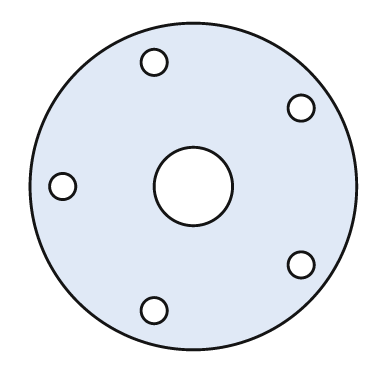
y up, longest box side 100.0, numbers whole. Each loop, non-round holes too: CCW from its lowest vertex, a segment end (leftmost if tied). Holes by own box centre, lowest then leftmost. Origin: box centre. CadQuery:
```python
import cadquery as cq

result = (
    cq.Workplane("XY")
    .moveTo(0.0, 0.0)
    .circle(50.0)
    .moveTo(-12.0, -38.0)
    .circle(4.0)
    .moveTo(33.0, -24.0)
    .circle(4.0)
    .moveTo(-40.0, 0.0)
    .circle(4.0)
    .moveTo(0.0, 0.0)
    .circle(12.0)
    .moveTo(33.0, 24.0)
    .circle(4.0)
    .moveTo(-12.0, 38.0)
    .circle(4.0)
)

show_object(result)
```